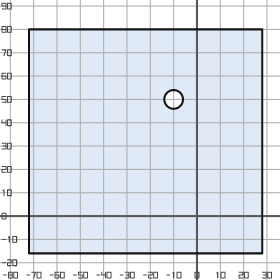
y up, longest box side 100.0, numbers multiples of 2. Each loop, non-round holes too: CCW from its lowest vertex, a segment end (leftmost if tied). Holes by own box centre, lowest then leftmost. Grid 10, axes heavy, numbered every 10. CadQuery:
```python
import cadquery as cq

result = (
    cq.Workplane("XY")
    .moveTo(-72.0, -16.0)
    .lineTo(28.0, -16.0)
    .lineTo(28.0, 80.0)
    .lineTo(-72.0, 80.0)
    .close()
    .moveTo(-10.0, 50.0)
    .circle(4.0)
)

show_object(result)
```